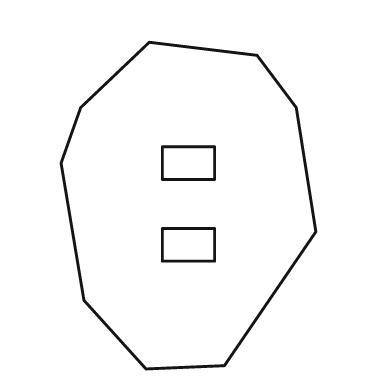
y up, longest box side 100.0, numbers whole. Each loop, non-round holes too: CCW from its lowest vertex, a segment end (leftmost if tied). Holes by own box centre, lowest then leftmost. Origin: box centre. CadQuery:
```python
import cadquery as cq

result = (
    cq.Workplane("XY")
    .moveTo(-13.0, -50.0)
    .lineTo(11.0, -49.0)
    .lineTo(39.0, -8.0)
    .lineTo(33.0, 30.0)
    .lineTo(21.0, 46.0)
    .lineTo(-12.0, 50.0)
    .lineTo(-33.0, 30.0)
    .lineTo(-39.0, 13.0)
    .lineTo(-32.0, -29.0)
    .close()
    .moveTo(-8.0, -17.0)
    .lineTo(8.0, -17.0)
    .lineTo(8.0, -7.0)
    .lineTo(-8.0, -7.0)
    .close()
    .moveTo(-8.0, 8.0)
    .lineTo(8.0, 8.0)
    .lineTo(8.0, 18.0)
    .lineTo(-8.0, 18.0)
    .close()
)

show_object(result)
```